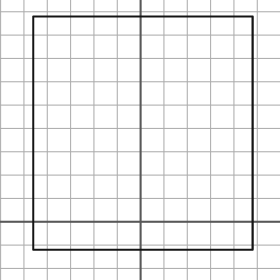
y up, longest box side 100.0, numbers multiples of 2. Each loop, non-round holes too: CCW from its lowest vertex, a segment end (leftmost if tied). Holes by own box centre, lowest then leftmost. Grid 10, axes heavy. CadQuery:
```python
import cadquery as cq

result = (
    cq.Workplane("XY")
    .moveTo(-46.0, -12.0)
    .lineTo(48.0, -12.0)
    .lineTo(48.0, 88.0)
    .lineTo(-46.0, 88.0)
    .close()
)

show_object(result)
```